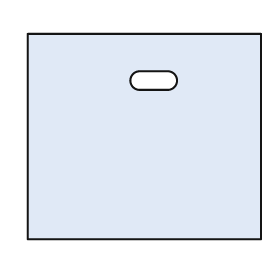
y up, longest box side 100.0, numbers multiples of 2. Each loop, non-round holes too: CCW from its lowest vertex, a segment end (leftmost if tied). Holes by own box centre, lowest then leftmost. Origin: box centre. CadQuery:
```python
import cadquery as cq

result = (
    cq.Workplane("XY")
    .moveTo(-50.0, -44.0)
    .lineTo(50.0, -44.0)
    .lineTo(50.0, 44.0)
    .lineTo(-50.0, 44.0)
    .close()
    .moveTo(-2.0, 20.0)
    .lineTo(10.0, 20.0)
    .threePointArc((14.0, 24.0), (10.0, 28.0))
    .lineTo(-2.0, 28.0)
    .threePointArc((-6.0, 24.0), (-2.0, 20.0))
    .close()
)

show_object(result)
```